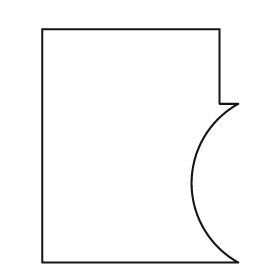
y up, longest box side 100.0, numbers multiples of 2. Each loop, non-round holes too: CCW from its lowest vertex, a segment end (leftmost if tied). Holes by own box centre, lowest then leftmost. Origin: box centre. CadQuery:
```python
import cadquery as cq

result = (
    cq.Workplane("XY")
    .moveTo(-42.0, -50.0)
    .lineTo(42.0, -50.0)
    .threePointArc((22.0, -16.0), (42.0, 18.0))
    .lineTo(34.0, 18.0)
    .lineTo(34.0, 50.0)
    .lineTo(-42.0, 50.0)
    .close()
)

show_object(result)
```